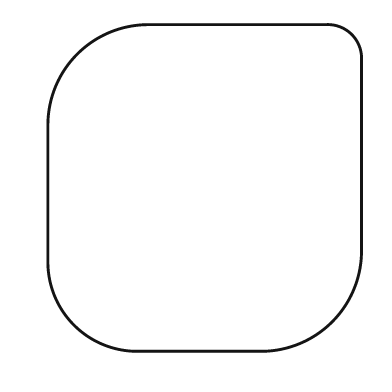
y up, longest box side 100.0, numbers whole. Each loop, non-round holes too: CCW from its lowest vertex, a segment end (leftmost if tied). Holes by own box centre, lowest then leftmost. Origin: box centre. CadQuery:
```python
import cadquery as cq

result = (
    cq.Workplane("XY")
    .moveTo(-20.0, -50.0)
    .lineTo(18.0, -50.0)
    .threePointArc((39.0, -41.0), (48.0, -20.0))
    .lineTo(48.0, 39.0)
    .threePointArc((45.0, 47.0), (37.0, 50.0))
    .lineTo(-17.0, 50.0)
    .threePointArc((-39.0, 41.0), (-48.0, 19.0))
    .lineTo(-48.0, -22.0)
    .threePointArc((-40.0, -42.0), (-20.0, -50.0))
    .close()
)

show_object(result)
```